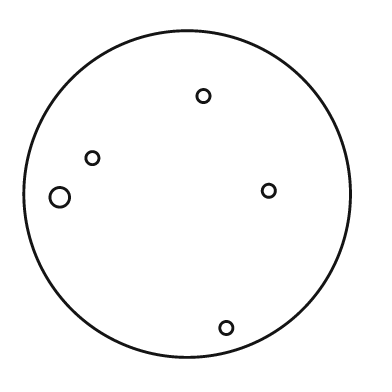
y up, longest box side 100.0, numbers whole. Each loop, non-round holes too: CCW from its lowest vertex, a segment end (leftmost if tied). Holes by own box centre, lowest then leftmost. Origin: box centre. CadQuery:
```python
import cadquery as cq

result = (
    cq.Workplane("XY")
    .moveTo(0.0, 0.0)
    .circle(50.0)
    .moveTo(12.0, -41.0)
    .circle(2.0)
    .moveTo(-39.0, -1.0)
    .circle(3.0)
    .moveTo(25.0, 1.0)
    .circle(2.0)
    .moveTo(-29.0, 11.0)
    .circle(2.0)
    .moveTo(5.0, 30.0)
    .circle(2.0)
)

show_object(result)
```